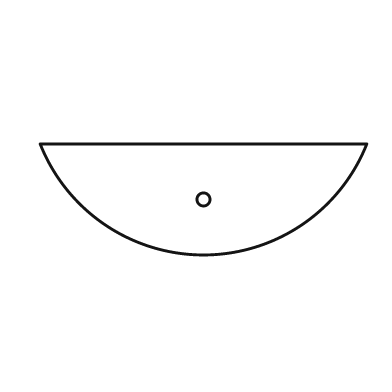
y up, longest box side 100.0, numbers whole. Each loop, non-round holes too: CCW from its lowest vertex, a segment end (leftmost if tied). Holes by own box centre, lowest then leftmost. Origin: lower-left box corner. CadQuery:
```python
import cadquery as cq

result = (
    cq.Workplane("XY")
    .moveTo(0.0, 34.0)
    .threePointArc((50.0, 0.0), (100.0, 34.0))
    .close()
    .moveTo(50.0, 17.0)
    .circle(2.0)
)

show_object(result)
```